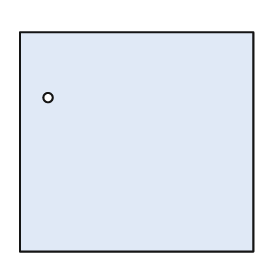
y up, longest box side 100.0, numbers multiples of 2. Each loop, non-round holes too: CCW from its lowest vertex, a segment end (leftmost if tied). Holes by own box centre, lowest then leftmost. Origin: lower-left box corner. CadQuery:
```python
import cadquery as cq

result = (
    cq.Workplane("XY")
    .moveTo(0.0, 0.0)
    .lineTo(100.0, 0.0)
    .lineTo(100.0, 94.0)
    .lineTo(0.0, 94.0)
    .close()
    .moveTo(12.0, 66.0)
    .circle(2.0)
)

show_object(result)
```